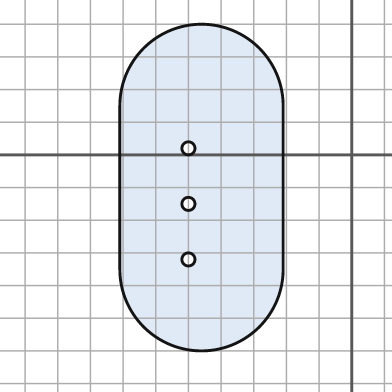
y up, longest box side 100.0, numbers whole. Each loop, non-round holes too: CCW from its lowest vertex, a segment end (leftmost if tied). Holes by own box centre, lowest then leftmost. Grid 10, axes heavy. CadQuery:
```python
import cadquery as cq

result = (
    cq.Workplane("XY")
    .moveTo(-71.0, -35.0)
    .threePointArc((-46.0, -60.0), (-21.0, -35.0))
    .lineTo(-21.0, 15.0)
    .threePointArc((-46.0, 40.0), (-71.0, 15.0))
    .close()
    .moveTo(-50.0, -32.0)
    .circle(2.0)
    .moveTo(-50.0, -15.0)
    .circle(2.0)
    .moveTo(-50.0, 2.0)
    .circle(2.0)
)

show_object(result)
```